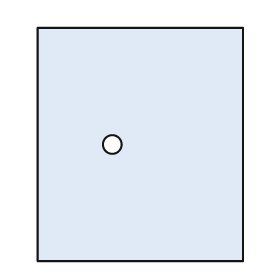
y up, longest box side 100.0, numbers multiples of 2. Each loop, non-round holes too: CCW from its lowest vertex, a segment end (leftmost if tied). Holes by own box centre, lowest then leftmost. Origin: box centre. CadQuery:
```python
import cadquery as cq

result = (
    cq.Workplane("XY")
    .moveTo(-44.0, -50.0)
    .lineTo(44.0, -50.0)
    .lineTo(44.0, 50.0)
    .lineTo(-44.0, 50.0)
    .close()
    .moveTo(-12.0, 0.0)
    .circle(4.0)
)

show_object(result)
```